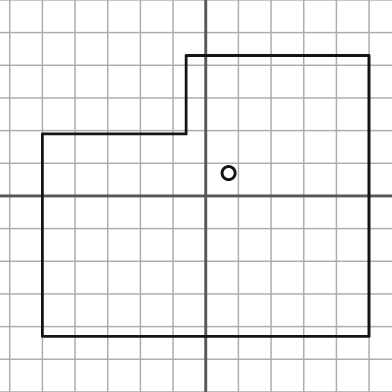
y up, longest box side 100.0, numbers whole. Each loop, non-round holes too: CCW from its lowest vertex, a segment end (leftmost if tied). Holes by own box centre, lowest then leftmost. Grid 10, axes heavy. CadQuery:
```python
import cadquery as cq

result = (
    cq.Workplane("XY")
    .moveTo(-50.0, -43.0)
    .lineTo(50.0, -43.0)
    .lineTo(50.0, 43.0)
    .lineTo(-6.0, 43.0)
    .lineTo(-6.0, 19.0)
    .lineTo(-50.0, 19.0)
    .close()
    .moveTo(7.0, 7.0)
    .circle(2.0)
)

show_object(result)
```